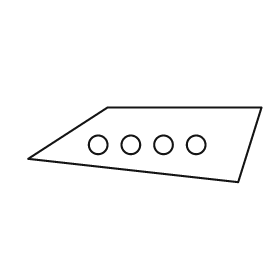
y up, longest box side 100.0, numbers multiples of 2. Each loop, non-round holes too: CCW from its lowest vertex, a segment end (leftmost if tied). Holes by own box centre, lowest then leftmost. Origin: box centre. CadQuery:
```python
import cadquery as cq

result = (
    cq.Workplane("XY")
    .moveTo(40.0, -16.0)
    .lineTo(50.0, 16.0)
    .lineTo(-16.0, 16.0)
    .lineTo(-50.0, -6.0)
    .close()
    .moveTo(-20.0, 0.0)
    .circle(4.0)
    .moveTo(-6.0, 0.0)
    .circle(4.0)
    .moveTo(8.0, 0.0)
    .circle(4.0)
    .moveTo(22.0, 0.0)
    .circle(4.0)
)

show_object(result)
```